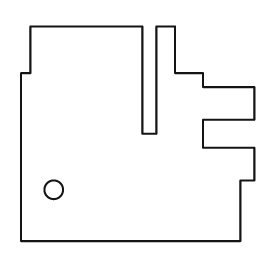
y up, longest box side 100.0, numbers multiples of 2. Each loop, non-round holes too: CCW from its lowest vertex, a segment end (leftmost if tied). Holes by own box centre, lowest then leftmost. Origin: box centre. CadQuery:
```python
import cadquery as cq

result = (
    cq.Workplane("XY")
    .moveTo(-50.0, -46.0)
    .lineTo(44.0, -46.0)
    .lineTo(44.0, -20.0)
    .lineTo(50.0, -20.0)
    .lineTo(50.0, -6.0)
    .lineTo(28.0, -6.0)
    .lineTo(28.0, 6.0)
    .lineTo(50.0, 6.0)
    .lineTo(50.0, 20.0)
    .lineTo(28.0, 20.0)
    .lineTo(28.0, 26.0)
    .lineTo(16.0, 26.0)
    .lineTo(16.0, 46.0)
    .lineTo(8.0, 46.0)
    .lineTo(8.0, 0.0)
    .lineTo(2.0, 0.0)
    .lineTo(2.0, 46.0)
    .lineTo(-46.0, 46.0)
    .lineTo(-46.0, 26.0)
    .lineTo(-50.0, 26.0)
    .close()
    .moveTo(-36.0, -24.0)
    .circle(4.0)
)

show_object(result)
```